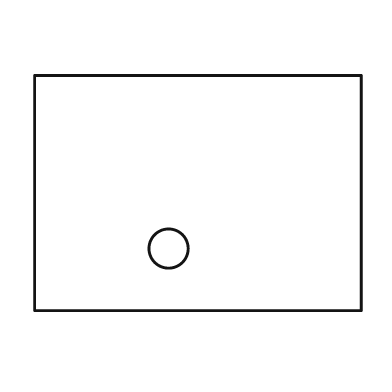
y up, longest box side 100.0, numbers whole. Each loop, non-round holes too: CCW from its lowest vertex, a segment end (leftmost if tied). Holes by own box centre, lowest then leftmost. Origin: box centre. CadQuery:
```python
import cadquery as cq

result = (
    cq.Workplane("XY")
    .moveTo(-50.0, -36.0)
    .lineTo(50.0, -36.0)
    .lineTo(50.0, 36.0)
    .lineTo(-50.0, 36.0)
    .close()
    .moveTo(-9.0, -17.0)
    .circle(6.0)
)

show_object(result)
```